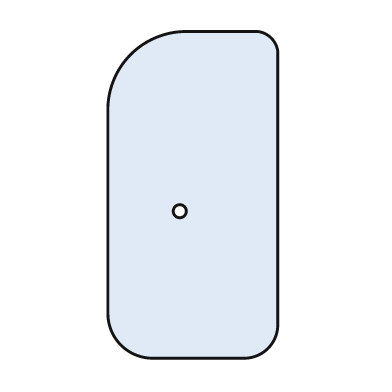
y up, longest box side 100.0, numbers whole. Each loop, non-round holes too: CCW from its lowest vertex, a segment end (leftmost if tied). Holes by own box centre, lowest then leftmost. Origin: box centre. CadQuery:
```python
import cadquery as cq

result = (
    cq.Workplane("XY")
    .moveTo(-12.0, -50.0)
    .lineTo(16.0, -50.0)
    .threePointArc((23.0, -47.0), (26.0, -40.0))
    .lineTo(26.0, 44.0)
    .threePointArc((24.0, 48.0), (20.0, 50.0))
    .lineTo(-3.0, 50.0)
    .threePointArc((-19.0, 43.0), (-26.0, 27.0))
    .lineTo(-26.0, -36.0)
    .threePointArc((-22.0, -46.0), (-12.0, -50.0))
    .close()
    .moveTo(-4.0, -5.0)
    .circle(2.0)
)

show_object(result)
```